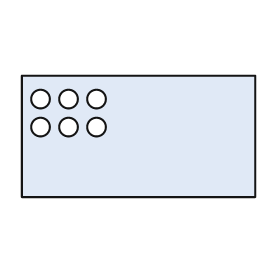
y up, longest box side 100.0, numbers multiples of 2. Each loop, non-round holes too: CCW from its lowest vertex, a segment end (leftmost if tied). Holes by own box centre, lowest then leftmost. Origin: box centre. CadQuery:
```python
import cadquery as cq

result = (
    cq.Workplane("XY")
    .moveTo(-50.0, -26.0)
    .lineTo(50.0, -26.0)
    .lineTo(50.0, 26.0)
    .lineTo(-50.0, 26.0)
    .close()
    .moveTo(-42.0, 4.0)
    .circle(4.0)
    .moveTo(-30.0, 4.0)
    .circle(4.0)
    .moveTo(-18.0, 4.0)
    .circle(4.0)
    .moveTo(-42.0, 16.0)
    .circle(4.0)
    .moveTo(-30.0, 16.0)
    .circle(4.0)
    .moveTo(-18.0, 16.0)
    .circle(4.0)
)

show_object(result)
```